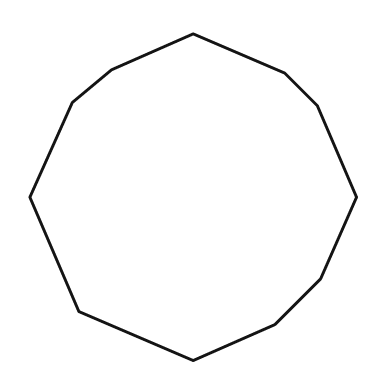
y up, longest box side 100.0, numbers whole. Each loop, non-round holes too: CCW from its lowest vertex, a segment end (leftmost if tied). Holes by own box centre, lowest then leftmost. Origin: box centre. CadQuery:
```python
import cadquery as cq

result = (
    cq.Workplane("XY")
    .moveTo(0.0, -50.0)
    .lineTo(25.0, -39.0)
    .lineTo(39.0, -25.0)
    .lineTo(50.0, 0.0)
    .lineTo(38.0, 28.0)
    .lineTo(28.0, 38.0)
    .lineTo(0.0, 50.0)
    .lineTo(-25.0, 39.0)
    .lineTo(-37.0, 29.0)
    .lineTo(-50.0, 0.0)
    .lineTo(-35.0, -35.0)
    .close()
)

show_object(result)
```